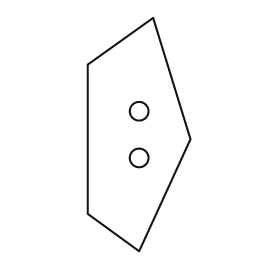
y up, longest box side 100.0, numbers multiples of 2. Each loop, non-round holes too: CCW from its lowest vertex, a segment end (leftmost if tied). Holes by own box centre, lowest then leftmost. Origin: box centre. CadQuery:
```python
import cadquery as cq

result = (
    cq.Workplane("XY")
    .moveTo(0.0, -50.0)
    .lineTo(22.0, -2.0)
    .lineTo(6.0, 50.0)
    .lineTo(-22.0, 30.0)
    .lineTo(-22.0, -34.0)
    .close()
    .moveTo(0.0, -10.0)
    .circle(4.0)
    .moveTo(0.0, 10.0)
    .circle(4.0)
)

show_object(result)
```